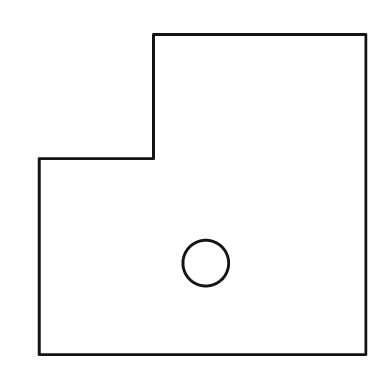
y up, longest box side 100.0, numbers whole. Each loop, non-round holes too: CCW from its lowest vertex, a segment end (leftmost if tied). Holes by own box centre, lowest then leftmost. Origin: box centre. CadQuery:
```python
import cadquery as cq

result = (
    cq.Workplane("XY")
    .moveTo(-50.0, -49.0)
    .lineTo(50.0, -49.0)
    .lineTo(50.0, 49.0)
    .lineTo(-15.0, 49.0)
    .lineTo(-15.0, 11.0)
    .lineTo(-50.0, 11.0)
    .close()
    .moveTo(1.0, -21.0)
    .circle(7.0)
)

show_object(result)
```